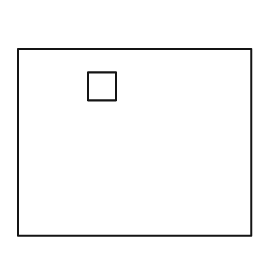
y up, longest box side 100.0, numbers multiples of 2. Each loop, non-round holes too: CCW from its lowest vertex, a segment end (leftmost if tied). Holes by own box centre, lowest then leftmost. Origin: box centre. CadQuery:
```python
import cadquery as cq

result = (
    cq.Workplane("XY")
    .moveTo(-50.0, -40.0)
    .lineTo(50.0, -40.0)
    .lineTo(50.0, 40.0)
    .lineTo(-50.0, 40.0)
    .close()
    .moveTo(-20.0, 18.0)
    .lineTo(-8.0, 18.0)
    .lineTo(-8.0, 30.0)
    .lineTo(-20.0, 30.0)
    .close()
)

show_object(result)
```